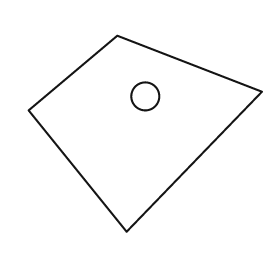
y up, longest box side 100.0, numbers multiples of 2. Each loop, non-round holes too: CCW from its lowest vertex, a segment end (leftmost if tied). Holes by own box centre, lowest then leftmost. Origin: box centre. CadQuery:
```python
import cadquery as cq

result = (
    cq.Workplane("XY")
    .moveTo(-8.0, -42.0)
    .lineTo(50.0, 18.0)
    .lineTo(-12.0, 42.0)
    .lineTo(-50.0, 10.0)
    .close()
    .moveTo(0.0, 16.0)
    .circle(6.0)
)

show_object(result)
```